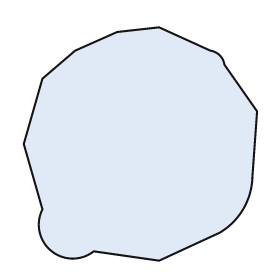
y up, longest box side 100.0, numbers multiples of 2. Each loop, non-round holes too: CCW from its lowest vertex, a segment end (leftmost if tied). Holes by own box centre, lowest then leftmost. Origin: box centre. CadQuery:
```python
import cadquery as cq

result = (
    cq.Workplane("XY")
    .moveTo(8.0, -50.0)
    .lineTo(34.0, -38.0)
    .threePointArc((44.0, -28.0), (48.0, -14.0))
    .lineTo(50.0, 14.0)
    .lineTo(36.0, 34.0)
    .threePointArc((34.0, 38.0), (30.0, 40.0))
    .lineTo(8.0, 50.0)
    .lineTo(-10.0, 48.0)
    .lineTo(-28.0, 40.0)
    .lineTo(-42.0, 28.0)
    .lineTo(-50.0, 0.0)
    .lineTo(-42.0, -28.0)
    .threePointArc((-38.0, -46.0), (-20.0, -46.0))
    .close()
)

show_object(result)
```